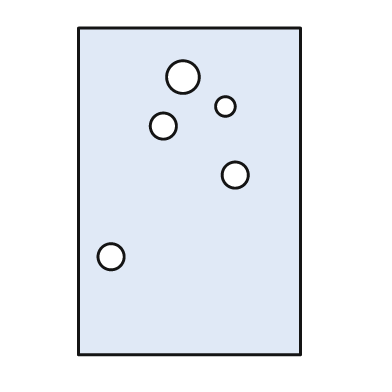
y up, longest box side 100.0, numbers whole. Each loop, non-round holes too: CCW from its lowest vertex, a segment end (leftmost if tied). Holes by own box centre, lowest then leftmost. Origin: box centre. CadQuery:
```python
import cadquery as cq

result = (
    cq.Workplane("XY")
    .moveTo(-34.0, -50.0)
    .lineTo(34.0, -50.0)
    .lineTo(34.0, 50.0)
    .lineTo(-34.0, 50.0)
    .close()
    .moveTo(-24.0, -20.0)
    .circle(4.0)
    .moveTo(14.0, 5.0)
    .circle(4.0)
    .moveTo(-8.0, 20.0)
    .circle(4.0)
    .moveTo(11.0, 26.0)
    .circle(3.0)
    .moveTo(-2.0, 35.0)
    .circle(5.0)
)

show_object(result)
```